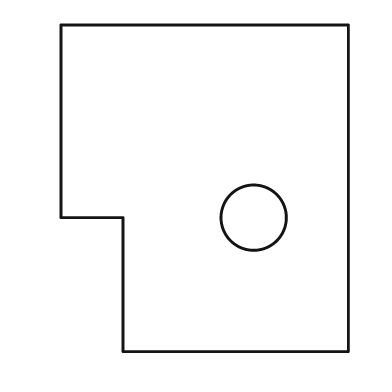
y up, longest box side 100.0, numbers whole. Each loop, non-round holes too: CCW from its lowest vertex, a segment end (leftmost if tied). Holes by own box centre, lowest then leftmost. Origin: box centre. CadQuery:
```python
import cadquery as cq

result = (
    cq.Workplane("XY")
    .moveTo(-25.0, -50.0)
    .lineTo(44.0, -50.0)
    .lineTo(44.0, 50.0)
    .lineTo(-44.0, 50.0)
    .lineTo(-44.0, -9.0)
    .lineTo(-25.0, -9.0)
    .close()
    .moveTo(15.0, -9.0)
    .circle(10.0)
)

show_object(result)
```